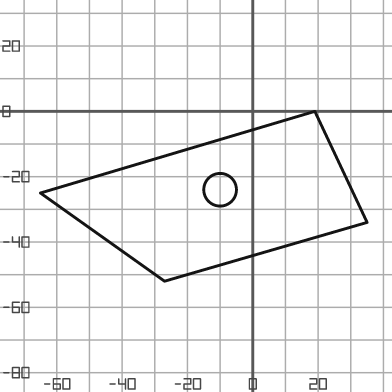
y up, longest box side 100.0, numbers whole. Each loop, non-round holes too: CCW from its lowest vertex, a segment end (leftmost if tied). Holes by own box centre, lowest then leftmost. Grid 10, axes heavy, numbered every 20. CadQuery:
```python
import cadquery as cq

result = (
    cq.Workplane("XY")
    .moveTo(-27.0, -52.0)
    .lineTo(35.0, -34.0)
    .lineTo(19.0, 0.0)
    .lineTo(-65.0, -25.0)
    .close()
    .moveTo(-10.0, -24.0)
    .circle(5.0)
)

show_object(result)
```